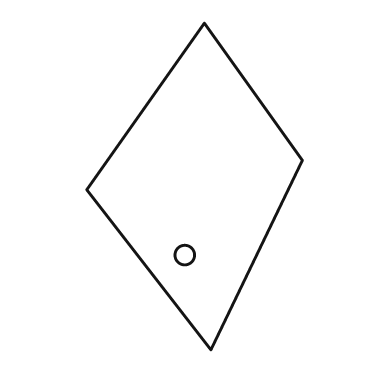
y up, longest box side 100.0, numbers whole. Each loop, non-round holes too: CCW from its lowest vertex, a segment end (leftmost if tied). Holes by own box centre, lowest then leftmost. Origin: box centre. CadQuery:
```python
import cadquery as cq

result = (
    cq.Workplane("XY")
    .moveTo(5.0, -50.0)
    .lineTo(33.0, 8.0)
    .lineTo(3.0, 50.0)
    .lineTo(-33.0, -1.0)
    .close()
    .moveTo(-3.0, -21.0)
    .circle(3.0)
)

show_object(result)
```